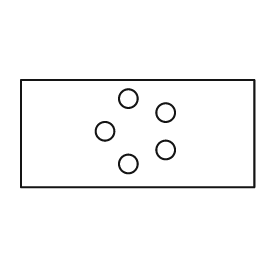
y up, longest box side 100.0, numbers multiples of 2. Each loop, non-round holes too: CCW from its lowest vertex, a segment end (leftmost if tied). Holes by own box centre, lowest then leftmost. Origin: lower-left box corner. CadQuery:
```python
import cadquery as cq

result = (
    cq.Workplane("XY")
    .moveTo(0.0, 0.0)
    .lineTo(100.0, 0.0)
    .lineTo(100.0, 46.0)
    .lineTo(0.0, 46.0)
    .close()
    .moveTo(46.0, 10.0)
    .circle(4.0)
    .moveTo(62.0, 16.0)
    .circle(4.0)
    .moveTo(36.0, 24.0)
    .circle(4.0)
    .moveTo(62.0, 32.0)
    .circle(4.0)
    .moveTo(46.0, 38.0)
    .circle(4.0)
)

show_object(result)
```